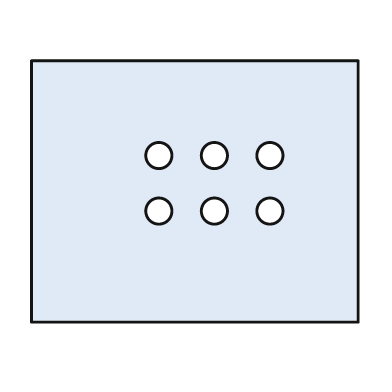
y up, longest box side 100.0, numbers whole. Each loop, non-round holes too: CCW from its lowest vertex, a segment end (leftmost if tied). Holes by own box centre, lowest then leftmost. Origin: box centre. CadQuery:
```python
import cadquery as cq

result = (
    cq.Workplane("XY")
    .moveTo(-50.0, -40.0)
    .lineTo(50.0, -40.0)
    .lineTo(50.0, 40.0)
    .lineTo(-50.0, 40.0)
    .close()
    .moveTo(-11.0, -6.0)
    .circle(4.0)
    .moveTo(6.0, -6.0)
    .circle(4.0)
    .moveTo(23.0, -6.0)
    .circle(4.0)
    .moveTo(-11.0, 11.0)
    .circle(4.0)
    .moveTo(6.0, 11.0)
    .circle(4.0)
    .moveTo(23.0, 11.0)
    .circle(4.0)
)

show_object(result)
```